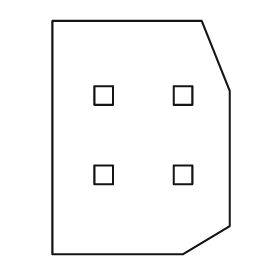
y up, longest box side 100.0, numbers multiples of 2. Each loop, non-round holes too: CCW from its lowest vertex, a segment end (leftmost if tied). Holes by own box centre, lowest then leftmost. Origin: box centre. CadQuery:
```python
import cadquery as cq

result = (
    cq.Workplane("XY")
    .moveTo(-38.0, -50.0)
    .lineTo(18.0, -50.0)
    .lineTo(38.0, -38.0)
    .lineTo(38.0, 20.0)
    .lineTo(26.0, 50.0)
    .lineTo(-38.0, 50.0)
    .close()
    .moveTo(-20.0, -20.0)
    .lineTo(-12.0, -20.0)
    .lineTo(-12.0, -12.0)
    .lineTo(-20.0, -12.0)
    .close()
    .moveTo(14.0, -20.0)
    .lineTo(22.0, -20.0)
    .lineTo(22.0, -12.0)
    .lineTo(14.0, -12.0)
    .close()
    .moveTo(-20.0, 14.0)
    .lineTo(-12.0, 14.0)
    .lineTo(-12.0, 22.0)
    .lineTo(-20.0, 22.0)
    .close()
    .moveTo(14.0, 14.0)
    .lineTo(22.0, 14.0)
    .lineTo(22.0, 22.0)
    .lineTo(14.0, 22.0)
    .close()
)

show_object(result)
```